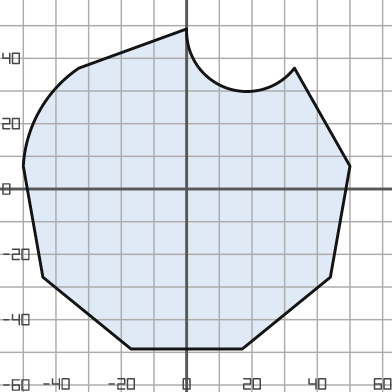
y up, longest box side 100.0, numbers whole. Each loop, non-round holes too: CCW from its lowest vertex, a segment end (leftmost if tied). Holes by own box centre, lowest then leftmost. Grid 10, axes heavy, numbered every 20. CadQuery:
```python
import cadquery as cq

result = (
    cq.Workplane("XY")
    .moveTo(-17.0, -49.0)
    .lineTo(17.0, -49.0)
    .lineTo(44.0, -27.0)
    .lineTo(50.0, 7.0)
    .lineTo(33.0, 37.0)
    .threePointArc((12.0, 31.0), (0.0, 49.0))
    .lineTo(-33.0, 37.0)
    .threePointArc((-45.0, 24.0), (-50.0, 7.0))
    .lineTo(-44.0, -27.0)
    .close()
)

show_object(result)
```